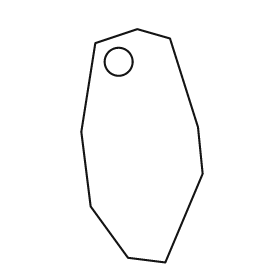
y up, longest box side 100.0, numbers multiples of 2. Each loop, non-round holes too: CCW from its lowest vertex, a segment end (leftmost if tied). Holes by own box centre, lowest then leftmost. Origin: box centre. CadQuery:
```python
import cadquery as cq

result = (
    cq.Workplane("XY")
    .moveTo(10.0, -50.0)
    .lineTo(26.0, -12.0)
    .lineTo(24.0, 8.0)
    .lineTo(12.0, 46.0)
    .lineTo(-2.0, 50.0)
    .lineTo(-20.0, 44.0)
    .lineTo(-26.0, 6.0)
    .lineTo(-22.0, -26.0)
    .lineTo(-6.0, -48.0)
    .close()
    .moveTo(-10.0, 36.0)
    .circle(6.0)
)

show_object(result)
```